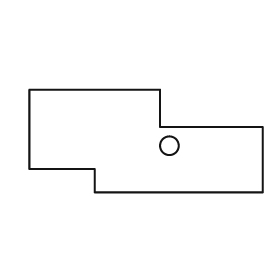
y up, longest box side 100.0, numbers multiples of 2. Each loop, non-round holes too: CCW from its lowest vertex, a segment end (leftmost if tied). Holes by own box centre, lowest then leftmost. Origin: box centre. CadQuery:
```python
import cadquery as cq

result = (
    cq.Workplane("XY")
    .moveTo(-22.0, -22.0)
    .lineTo(50.0, -22.0)
    .lineTo(50.0, 6.0)
    .lineTo(6.0, 6.0)
    .lineTo(6.0, 22.0)
    .lineTo(-50.0, 22.0)
    .lineTo(-50.0, -12.0)
    .lineTo(-22.0, -12.0)
    .close()
    .moveTo(10.0, -2.0)
    .circle(4.0)
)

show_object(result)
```